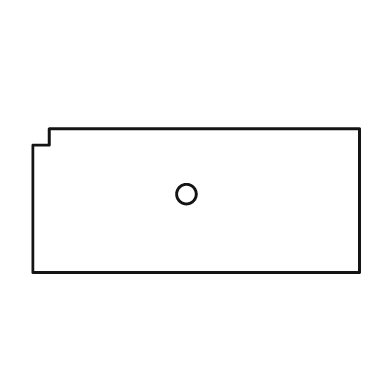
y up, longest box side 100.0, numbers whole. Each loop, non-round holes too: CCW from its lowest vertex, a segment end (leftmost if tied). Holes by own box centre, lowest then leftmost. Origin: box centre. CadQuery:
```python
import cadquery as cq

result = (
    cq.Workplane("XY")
    .moveTo(-50.0, -22.0)
    .lineTo(50.0, -22.0)
    .lineTo(50.0, 22.0)
    .lineTo(-45.0, 22.0)
    .lineTo(-45.0, 17.0)
    .lineTo(-50.0, 17.0)
    .close()
    .moveTo(-3.0, 2.0)
    .circle(3.0)
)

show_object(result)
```